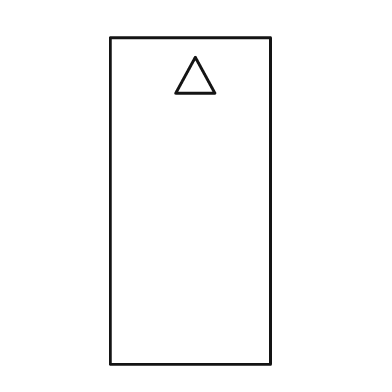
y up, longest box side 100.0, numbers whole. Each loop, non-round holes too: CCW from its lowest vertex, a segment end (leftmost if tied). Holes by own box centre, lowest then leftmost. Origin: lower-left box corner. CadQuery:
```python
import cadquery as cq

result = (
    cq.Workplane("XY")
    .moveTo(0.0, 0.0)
    .lineTo(49.0, 0.0)
    .lineTo(49.0, 100.0)
    .lineTo(0.0, 100.0)
    .close()
    .moveTo(20.0, 83.0)
    .lineTo(32.0, 83.0)
    .lineTo(26.0, 94.0)
    .close()
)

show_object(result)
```